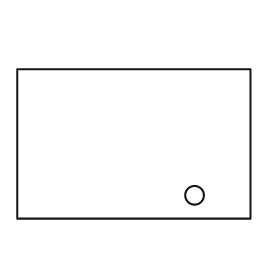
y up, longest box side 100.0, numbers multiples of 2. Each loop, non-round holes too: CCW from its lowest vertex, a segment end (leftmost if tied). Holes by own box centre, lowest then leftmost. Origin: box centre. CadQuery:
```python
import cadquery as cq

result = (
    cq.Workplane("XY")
    .moveTo(-50.0, -32.0)
    .lineTo(50.0, -32.0)
    .lineTo(50.0, 32.0)
    .lineTo(-50.0, 32.0)
    .close()
    .moveTo(26.0, -22.0)
    .circle(4.0)
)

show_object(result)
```